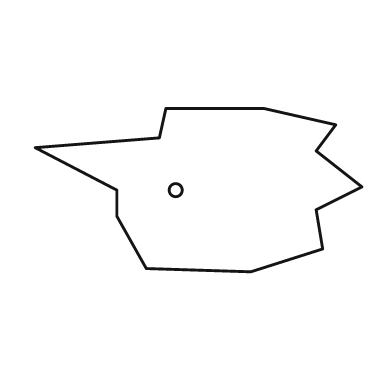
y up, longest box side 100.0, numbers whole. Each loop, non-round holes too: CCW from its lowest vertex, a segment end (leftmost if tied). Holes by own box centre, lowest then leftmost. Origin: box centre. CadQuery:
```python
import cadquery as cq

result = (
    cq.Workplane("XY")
    .moveTo(16.0, -25.0)
    .lineTo(38.0, -18.0)
    .lineTo(36.0, -6.0)
    .lineTo(50.0, 1.0)
    .lineTo(36.0, 12.0)
    .lineTo(42.0, 20.0)
    .lineTo(20.0, 25.0)
    .lineTo(-10.0, 25.0)
    .lineTo(-12.0, 16.0)
    .lineTo(-50.0, 13.0)
    .lineTo(-25.0, 0.0)
    .lineTo(-25.0, -8.0)
    .lineTo(-16.0, -24.0)
    .close()
    .moveTo(-7.0, 0.0)
    .circle(2.0)
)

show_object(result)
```